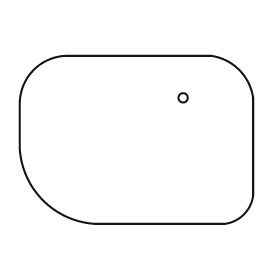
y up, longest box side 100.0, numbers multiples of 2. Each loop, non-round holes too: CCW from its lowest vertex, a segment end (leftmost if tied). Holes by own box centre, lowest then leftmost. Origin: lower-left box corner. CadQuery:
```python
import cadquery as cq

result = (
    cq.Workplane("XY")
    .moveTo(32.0, 0.0)
    .lineTo(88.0, 0.0)
    .threePointArc((96.0, 4.0), (100.0, 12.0))
    .lineTo(100.0, 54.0)
    .threePointArc((94.0, 66.0), (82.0, 72.0))
    .lineTo(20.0, 72.0)
    .threePointArc((6.0, 66.0), (0.0, 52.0))
    .lineTo(0.0, 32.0)
    .threePointArc((10.0, 10.0), (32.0, 0.0))
    .close()
    .moveTo(70.0, 54.0)
    .circle(2.0)
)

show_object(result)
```